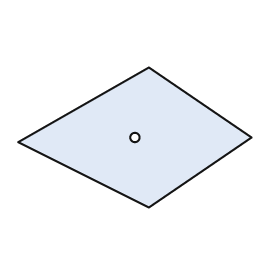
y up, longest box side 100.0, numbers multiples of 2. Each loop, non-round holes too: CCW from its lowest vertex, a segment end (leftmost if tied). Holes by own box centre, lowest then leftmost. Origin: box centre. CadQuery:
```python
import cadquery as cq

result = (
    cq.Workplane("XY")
    .moveTo(6.0, -30.0)
    .lineTo(50.0, 0.0)
    .lineTo(6.0, 30.0)
    .lineTo(-50.0, -2.0)
    .close()
    .moveTo(0.0, 0.0)
    .circle(2.0)
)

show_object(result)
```